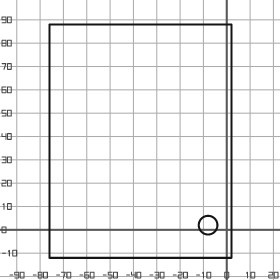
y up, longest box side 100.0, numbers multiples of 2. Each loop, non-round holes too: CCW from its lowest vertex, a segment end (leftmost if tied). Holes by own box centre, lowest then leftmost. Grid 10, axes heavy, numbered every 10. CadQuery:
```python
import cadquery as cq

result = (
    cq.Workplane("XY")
    .moveTo(-76.0, -12.0)
    .lineTo(2.0, -12.0)
    .lineTo(2.0, 88.0)
    .lineTo(-76.0, 88.0)
    .close()
    .moveTo(-8.0, 2.0)
    .circle(4.0)
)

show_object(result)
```